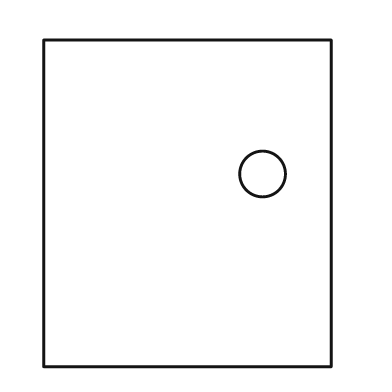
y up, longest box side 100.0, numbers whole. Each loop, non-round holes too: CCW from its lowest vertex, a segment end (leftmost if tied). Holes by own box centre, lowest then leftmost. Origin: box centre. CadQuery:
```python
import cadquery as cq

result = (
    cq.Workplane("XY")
    .moveTo(-44.0, -50.0)
    .lineTo(44.0, -50.0)
    .lineTo(44.0, 50.0)
    .lineTo(-44.0, 50.0)
    .close()
    .moveTo(23.0, 9.0)
    .circle(7.0)
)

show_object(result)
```